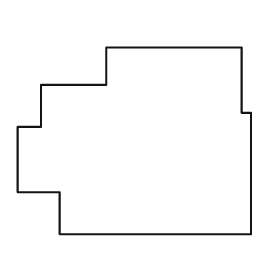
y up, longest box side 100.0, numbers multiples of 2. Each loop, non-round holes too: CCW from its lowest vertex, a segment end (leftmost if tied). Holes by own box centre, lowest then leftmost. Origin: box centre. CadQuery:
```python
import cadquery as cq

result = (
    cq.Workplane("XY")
    .moveTo(-32.0, -40.0)
    .lineTo(50.0, -40.0)
    .lineTo(50.0, 12.0)
    .lineTo(46.0, 12.0)
    .lineTo(46.0, 40.0)
    .lineTo(-12.0, 40.0)
    .lineTo(-12.0, 24.0)
    .lineTo(-40.0, 24.0)
    .lineTo(-40.0, 6.0)
    .lineTo(-50.0, 6.0)
    .lineTo(-50.0, -22.0)
    .lineTo(-32.0, -22.0)
    .close()
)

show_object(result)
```